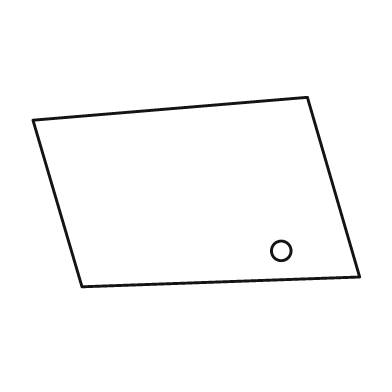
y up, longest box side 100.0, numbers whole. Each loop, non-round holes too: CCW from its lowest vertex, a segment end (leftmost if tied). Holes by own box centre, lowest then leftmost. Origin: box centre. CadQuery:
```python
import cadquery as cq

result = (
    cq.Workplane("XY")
    .moveTo(-35.0, -29.0)
    .lineTo(50.0, -26.0)
    .lineTo(34.0, 29.0)
    .lineTo(-50.0, 22.0)
    .close()
    .moveTo(26.0, -18.0)
    .circle(3.0)
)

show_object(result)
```